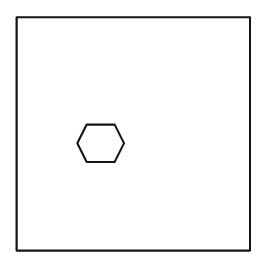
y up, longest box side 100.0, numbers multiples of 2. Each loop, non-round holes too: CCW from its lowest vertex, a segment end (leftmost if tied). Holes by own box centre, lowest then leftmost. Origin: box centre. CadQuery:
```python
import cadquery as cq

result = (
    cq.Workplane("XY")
    .moveTo(-50.0, -50.0)
    .lineTo(50.0, -50.0)
    .lineTo(50.0, 50.0)
    .lineTo(-50.0, 50.0)
    .close()
    .moveTo(-20.0, -12.0)
    .lineTo(-8.0, -12.0)
    .lineTo(-4.0, -4.0)
    .lineTo(-8.0, 4.0)
    .lineTo(-20.0, 4.0)
    .lineTo(-24.0, -4.0)
    .close()
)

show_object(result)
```